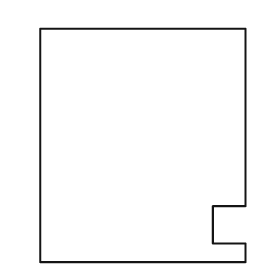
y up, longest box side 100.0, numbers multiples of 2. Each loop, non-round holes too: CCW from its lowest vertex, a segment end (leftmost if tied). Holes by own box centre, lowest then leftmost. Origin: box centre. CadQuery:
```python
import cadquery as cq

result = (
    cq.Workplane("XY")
    .moveTo(-44.0, -50.0)
    .lineTo(44.0, -50.0)
    .lineTo(44.0, -42.0)
    .lineTo(30.0, -42.0)
    .lineTo(30.0, -26.0)
    .lineTo(44.0, -26.0)
    .lineTo(44.0, 50.0)
    .lineTo(-44.0, 50.0)
    .close()
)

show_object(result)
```